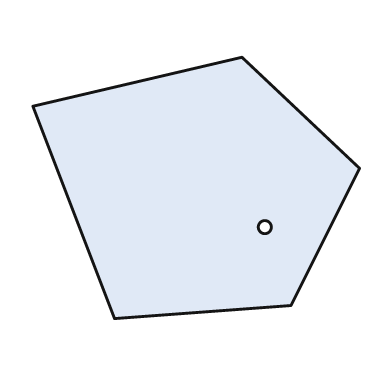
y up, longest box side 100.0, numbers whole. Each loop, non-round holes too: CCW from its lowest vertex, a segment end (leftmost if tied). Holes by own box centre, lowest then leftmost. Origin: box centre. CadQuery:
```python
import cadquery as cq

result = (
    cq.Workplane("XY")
    .moveTo(-25.0, -40.0)
    .lineTo(29.0, -36.0)
    .lineTo(50.0, 6.0)
    .lineTo(14.0, 40.0)
    .lineTo(-50.0, 25.0)
    .close()
    .moveTo(21.0, -12.0)
    .circle(2.0)
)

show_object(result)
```